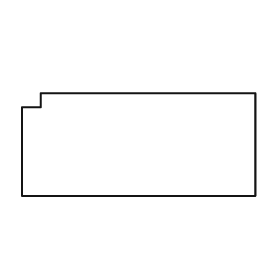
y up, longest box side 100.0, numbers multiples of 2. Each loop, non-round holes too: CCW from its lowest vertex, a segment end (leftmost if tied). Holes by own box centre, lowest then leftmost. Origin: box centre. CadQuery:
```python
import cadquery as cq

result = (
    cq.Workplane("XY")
    .moveTo(-50.0, -22.0)
    .lineTo(50.0, -22.0)
    .lineTo(50.0, 22.0)
    .lineTo(-42.0, 22.0)
    .lineTo(-42.0, 16.0)
    .lineTo(-50.0, 16.0)
    .close()
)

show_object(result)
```